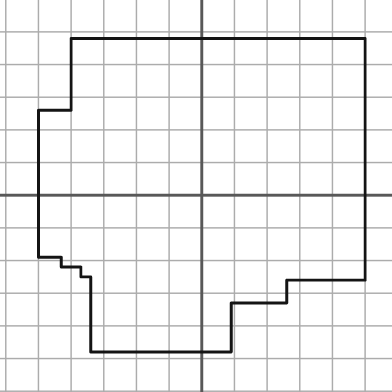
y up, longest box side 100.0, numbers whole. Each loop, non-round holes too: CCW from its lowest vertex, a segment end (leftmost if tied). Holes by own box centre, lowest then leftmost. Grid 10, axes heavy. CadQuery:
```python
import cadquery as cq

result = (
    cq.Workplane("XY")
    .moveTo(-34.0, -48.0)
    .lineTo(9.0, -48.0)
    .lineTo(9.0, -33.0)
    .lineTo(26.0, -33.0)
    .lineTo(26.0, -26.0)
    .lineTo(50.0, -26.0)
    .lineTo(50.0, 48.0)
    .lineTo(-40.0, 48.0)
    .lineTo(-40.0, 26.0)
    .lineTo(-50.0, 26.0)
    .lineTo(-50.0, -19.0)
    .lineTo(-43.0, -19.0)
    .lineTo(-43.0, -22.0)
    .lineTo(-37.0, -22.0)
    .lineTo(-37.0, -25.0)
    .lineTo(-34.0, -25.0)
    .close()
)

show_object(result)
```